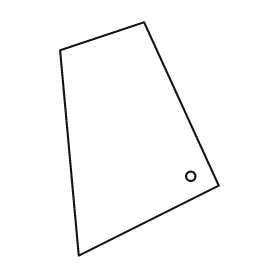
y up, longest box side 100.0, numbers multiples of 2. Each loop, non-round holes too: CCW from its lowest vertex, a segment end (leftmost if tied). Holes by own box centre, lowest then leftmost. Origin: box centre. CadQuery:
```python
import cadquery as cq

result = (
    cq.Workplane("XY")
    .moveTo(-26.0, -50.0)
    .lineTo(34.0, -20.0)
    .lineTo(2.0, 50.0)
    .lineTo(-34.0, 38.0)
    .close()
    .moveTo(22.0, -16.0)
    .circle(2.0)
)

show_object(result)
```